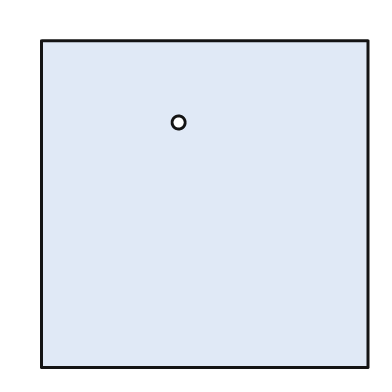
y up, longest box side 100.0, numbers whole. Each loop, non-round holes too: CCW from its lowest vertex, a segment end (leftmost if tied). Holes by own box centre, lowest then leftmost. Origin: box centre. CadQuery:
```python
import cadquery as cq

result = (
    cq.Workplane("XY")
    .moveTo(-50.0, -50.0)
    .lineTo(50.0, -50.0)
    .lineTo(50.0, 50.0)
    .lineTo(-50.0, 50.0)
    .close()
    .moveTo(-8.0, 25.0)
    .circle(2.0)
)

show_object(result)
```